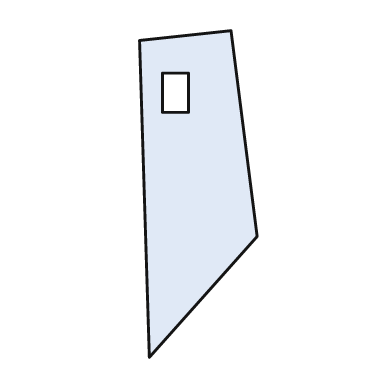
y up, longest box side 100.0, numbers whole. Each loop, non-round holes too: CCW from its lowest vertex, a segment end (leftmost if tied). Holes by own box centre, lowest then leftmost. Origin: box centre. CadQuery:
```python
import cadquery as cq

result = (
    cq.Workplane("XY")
    .moveTo(-15.0, -50.0)
    .lineTo(18.0, -13.0)
    .lineTo(10.0, 50.0)
    .lineTo(-18.0, 47.0)
    .close()
    .moveTo(-11.0, 25.0)
    .lineTo(-3.0, 25.0)
    .lineTo(-3.0, 37.0)
    .lineTo(-11.0, 37.0)
    .close()
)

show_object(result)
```